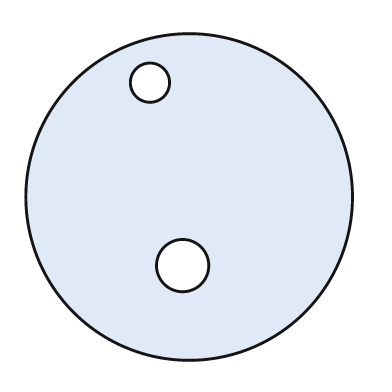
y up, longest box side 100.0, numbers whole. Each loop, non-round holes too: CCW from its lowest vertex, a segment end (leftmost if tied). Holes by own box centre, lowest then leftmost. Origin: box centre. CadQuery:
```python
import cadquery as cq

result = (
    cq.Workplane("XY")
    .moveTo(0.0, 0.0)
    .circle(50.0)
    .moveTo(-2.0, -21.0)
    .circle(8.0)
    .moveTo(-12.0, 35.0)
    .circle(6.0)
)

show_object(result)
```